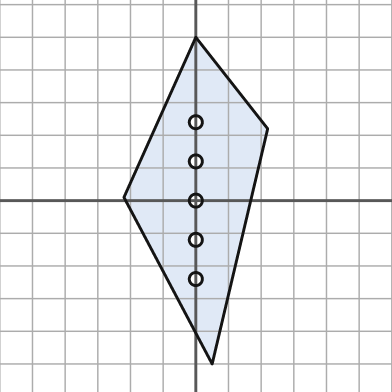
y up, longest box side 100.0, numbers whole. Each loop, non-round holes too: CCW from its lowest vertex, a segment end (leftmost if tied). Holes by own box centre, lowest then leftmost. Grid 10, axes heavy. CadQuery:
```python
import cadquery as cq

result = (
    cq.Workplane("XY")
    .moveTo(5.0, -50.0)
    .lineTo(22.0, 22.0)
    .lineTo(0.0, 50.0)
    .lineTo(-22.0, 1.0)
    .close()
    .moveTo(0.0, -24.0)
    .circle(2.0)
    .moveTo(0.0, -12.0)
    .circle(2.0)
    .moveTo(0.0, 0.0)
    .circle(2.0)
    .moveTo(0.0, 12.0)
    .circle(2.0)
    .moveTo(0.0, 24.0)
    .circle(2.0)
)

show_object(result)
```